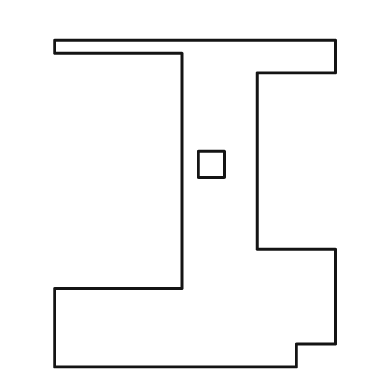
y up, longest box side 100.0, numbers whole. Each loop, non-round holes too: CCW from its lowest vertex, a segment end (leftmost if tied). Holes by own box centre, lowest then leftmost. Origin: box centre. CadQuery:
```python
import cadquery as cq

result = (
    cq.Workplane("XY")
    .moveTo(-43.0, -50.0)
    .lineTo(31.0, -50.0)
    .lineTo(31.0, -43.0)
    .lineTo(43.0, -43.0)
    .lineTo(43.0, -14.0)
    .lineTo(19.0, -14.0)
    .lineTo(19.0, 40.0)
    .lineTo(43.0, 40.0)
    .lineTo(43.0, 50.0)
    .lineTo(-43.0, 50.0)
    .lineTo(-43.0, 46.0)
    .lineTo(-4.0, 46.0)
    .lineTo(-4.0, -26.0)
    .lineTo(-43.0, -26.0)
    .close()
    .moveTo(1.0, 8.0)
    .lineTo(9.0, 8.0)
    .lineTo(9.0, 16.0)
    .lineTo(1.0, 16.0)
    .close()
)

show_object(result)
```